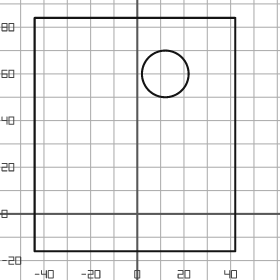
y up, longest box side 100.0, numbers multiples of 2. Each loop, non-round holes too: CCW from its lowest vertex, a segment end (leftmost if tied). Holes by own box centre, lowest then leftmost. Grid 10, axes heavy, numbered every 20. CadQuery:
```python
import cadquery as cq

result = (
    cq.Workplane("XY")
    .moveTo(-44.0, -16.0)
    .lineTo(42.0, -16.0)
    .lineTo(42.0, 84.0)
    .lineTo(-44.0, 84.0)
    .close()
    .moveTo(12.0, 60.0)
    .circle(10.0)
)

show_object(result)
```